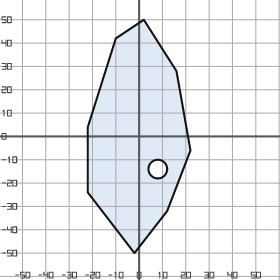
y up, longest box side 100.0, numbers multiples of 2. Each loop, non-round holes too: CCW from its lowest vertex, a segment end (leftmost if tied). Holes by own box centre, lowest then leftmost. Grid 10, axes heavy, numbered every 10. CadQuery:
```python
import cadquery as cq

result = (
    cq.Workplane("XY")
    .moveTo(-2.0, -50.0)
    .lineTo(12.0, -32.0)
    .lineTo(22.0, -6.0)
    .lineTo(16.0, 28.0)
    .lineTo(2.0, 50.0)
    .lineTo(-10.0, 42.0)
    .lineTo(-22.0, 4.0)
    .lineTo(-22.0, -24.0)
    .close()
    .moveTo(8.0, -14.0)
    .circle(4.0)
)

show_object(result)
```